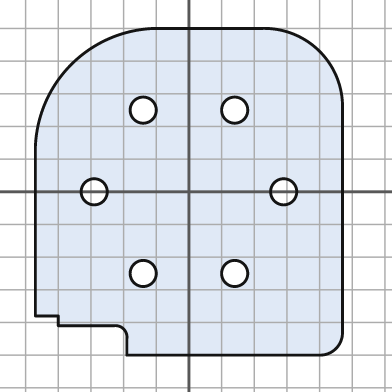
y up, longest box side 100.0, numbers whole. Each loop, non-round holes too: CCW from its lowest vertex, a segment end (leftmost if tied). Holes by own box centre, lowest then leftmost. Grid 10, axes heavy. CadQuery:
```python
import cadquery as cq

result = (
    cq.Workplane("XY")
    .moveTo(-19.0, -50.0)
    .lineTo(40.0, -50.0)
    .threePointArc((45.0, -48.0), (47.0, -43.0))
    .lineTo(47.0, 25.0)
    .threePointArc((40.0, 43.0), (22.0, 50.0))
    .lineTo(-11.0, 50.0)
    .threePointArc((-36.0, 39.0), (-47.0, 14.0))
    .lineTo(-47.0, -38.0)
    .lineTo(-40.0, -38.0)
    .lineTo(-40.0, -41.0)
    .lineTo(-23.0, -41.0)
    .threePointArc((-20.0, -42.0), (-19.0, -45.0))
    .close()
    .moveTo(-14.0, -25.0)
    .circle(4.0)
    .moveTo(14.0, -25.0)
    .circle(4.0)
    .moveTo(-29.0, 0.0)
    .circle(4.0)
    .moveTo(29.0, 0.0)
    .circle(4.0)
    .moveTo(-14.0, 25.0)
    .circle(4.0)
    .moveTo(14.0, 25.0)
    .circle(4.0)
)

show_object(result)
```